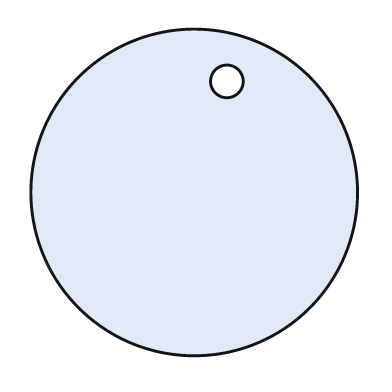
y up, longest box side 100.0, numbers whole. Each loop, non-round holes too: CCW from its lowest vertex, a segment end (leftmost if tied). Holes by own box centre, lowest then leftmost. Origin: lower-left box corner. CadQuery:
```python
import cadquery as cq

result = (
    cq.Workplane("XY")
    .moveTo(50.0, 50.0)
    .circle(50.0)
    .moveTo(60.0, 84.0)
    .circle(5.0)
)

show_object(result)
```